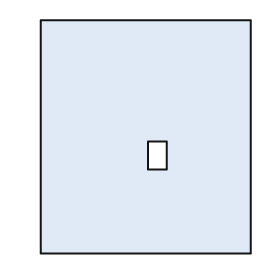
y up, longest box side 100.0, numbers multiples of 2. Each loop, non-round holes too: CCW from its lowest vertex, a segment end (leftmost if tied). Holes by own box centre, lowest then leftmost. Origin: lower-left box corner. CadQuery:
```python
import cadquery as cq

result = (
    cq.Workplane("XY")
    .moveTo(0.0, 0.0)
    .lineTo(90.0, 0.0)
    .lineTo(90.0, 100.0)
    .lineTo(0.0, 100.0)
    .close()
    .moveTo(46.0, 36.0)
    .lineTo(54.0, 36.0)
    .lineTo(54.0, 48.0)
    .lineTo(46.0, 48.0)
    .close()
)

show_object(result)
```